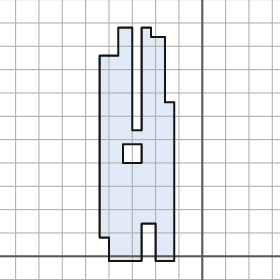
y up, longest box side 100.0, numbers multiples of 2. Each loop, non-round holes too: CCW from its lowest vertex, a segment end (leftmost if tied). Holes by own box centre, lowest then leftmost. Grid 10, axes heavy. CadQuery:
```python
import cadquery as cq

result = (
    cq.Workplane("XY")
    .moveTo(-40.0, -2.0)
    .lineTo(-26.0, -2.0)
    .lineTo(-26.0, 14.0)
    .lineTo(-20.0, 14.0)
    .lineTo(-20.0, -2.0)
    .lineTo(-12.0, -2.0)
    .lineTo(-12.0, 66.0)
    .lineTo(-16.0, 66.0)
    .lineTo(-16.0, 94.0)
    .lineTo(-22.0, 94.0)
    .lineTo(-22.0, 98.0)
    .lineTo(-26.0, 98.0)
    .lineTo(-26.0, 54.0)
    .lineTo(-30.0, 54.0)
    .lineTo(-30.0, 98.0)
    .lineTo(-36.0, 98.0)
    .lineTo(-36.0, 86.0)
    .lineTo(-44.0, 86.0)
    .lineTo(-44.0, 8.0)
    .lineTo(-40.0, 8.0)
    .close()
    .moveTo(-34.0, 40.0)
    .lineTo(-26.0, 40.0)
    .lineTo(-26.0, 48.0)
    .lineTo(-34.0, 48.0)
    .close()
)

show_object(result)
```